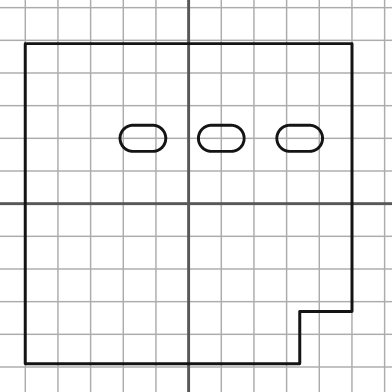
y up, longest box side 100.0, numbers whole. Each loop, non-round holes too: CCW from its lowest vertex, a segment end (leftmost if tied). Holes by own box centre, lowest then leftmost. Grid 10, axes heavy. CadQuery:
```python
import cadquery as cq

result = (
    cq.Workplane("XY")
    .moveTo(-50.0, -49.0)
    .lineTo(34.0, -49.0)
    .lineTo(34.0, -33.0)
    .lineTo(50.0, -33.0)
    .lineTo(50.0, 49.0)
    .lineTo(-50.0, 49.0)
    .close()
    .moveTo(-17.0, 16.0)
    .lineTo(-11.0, 16.0)
    .threePointArc((-7.0, 20.0), (-11.0, 24.0))
    .lineTo(-17.0, 24.0)
    .threePointArc((-21.0, 20.0), (-17.0, 16.0))
    .close()
    .moveTo(7.0, 16.0)
    .lineTo(13.0, 16.0)
    .threePointArc((17.0, 20.0), (13.0, 24.0))
    .lineTo(7.0, 24.0)
    .threePointArc((3.0, 20.0), (7.0, 16.0))
    .close()
    .moveTo(31.0, 16.0)
    .lineTo(37.0, 16.0)
    .threePointArc((41.0, 20.0), (37.0, 24.0))
    .lineTo(31.0, 24.0)
    .threePointArc((27.0, 20.0), (31.0, 16.0))
    .close()
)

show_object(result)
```